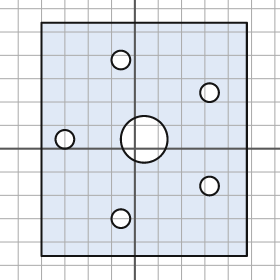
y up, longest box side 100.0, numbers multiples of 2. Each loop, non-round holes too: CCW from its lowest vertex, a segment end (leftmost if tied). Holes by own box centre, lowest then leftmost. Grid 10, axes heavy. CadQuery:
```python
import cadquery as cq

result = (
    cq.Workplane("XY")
    .moveTo(-40.0, -46.0)
    .lineTo(48.0, -46.0)
    .lineTo(48.0, 54.0)
    .lineTo(-40.0, 54.0)
    .close()
    .moveTo(-6.0, -30.0)
    .circle(4.0)
    .moveTo(32.0, -16.0)
    .circle(4.0)
    .moveTo(-30.0, 4.0)
    .circle(4.0)
    .moveTo(4.0, 4.0)
    .circle(10.0)
    .moveTo(32.0, 24.0)
    .circle(4.0)
    .moveTo(-6.0, 38.0)
    .circle(4.0)
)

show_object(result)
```